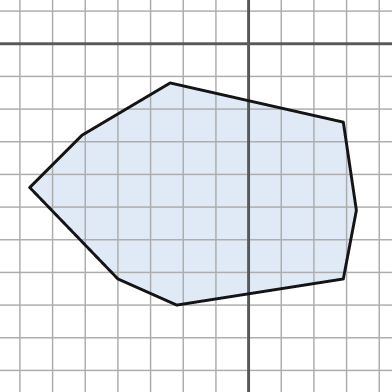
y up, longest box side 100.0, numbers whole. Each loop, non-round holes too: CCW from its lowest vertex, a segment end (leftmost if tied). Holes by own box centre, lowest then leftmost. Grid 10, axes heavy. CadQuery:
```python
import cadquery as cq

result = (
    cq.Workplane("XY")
    .moveTo(-22.0, -80.0)
    .lineTo(29.0, -72.0)
    .lineTo(33.0, -51.0)
    .lineTo(29.0, -24.0)
    .lineTo(-24.0, -12.0)
    .lineTo(-51.0, -28.0)
    .lineTo(-67.0, -44.0)
    .lineTo(-40.0, -72.0)
    .close()
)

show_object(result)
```